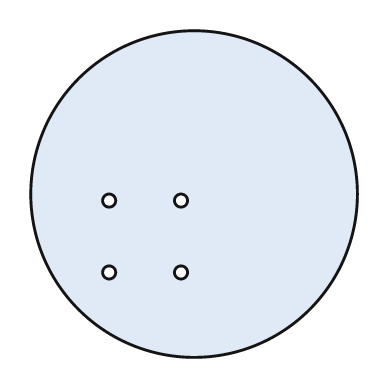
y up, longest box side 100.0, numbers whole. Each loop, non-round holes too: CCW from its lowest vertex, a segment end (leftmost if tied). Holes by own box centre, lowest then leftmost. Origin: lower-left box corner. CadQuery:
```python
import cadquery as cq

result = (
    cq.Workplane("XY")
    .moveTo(50.0, 50.0)
    .circle(50.0)
    .moveTo(24.0, 26.0)
    .circle(2.0)
    .moveTo(46.0, 26.0)
    .circle(2.0)
    .moveTo(24.0, 48.0)
    .circle(2.0)
    .moveTo(46.0, 48.0)
    .circle(2.0)
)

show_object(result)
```